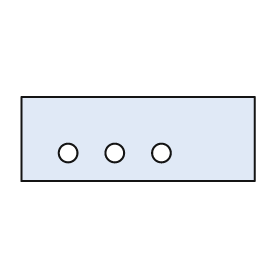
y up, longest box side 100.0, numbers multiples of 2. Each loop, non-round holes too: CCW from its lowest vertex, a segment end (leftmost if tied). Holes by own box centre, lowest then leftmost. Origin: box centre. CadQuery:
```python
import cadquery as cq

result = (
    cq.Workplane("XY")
    .moveTo(-50.0, -18.0)
    .lineTo(50.0, -18.0)
    .lineTo(50.0, 18.0)
    .lineTo(-50.0, 18.0)
    .close()
    .moveTo(-30.0, -6.0)
    .circle(4.0)
    .moveTo(-10.0, -6.0)
    .circle(4.0)
    .moveTo(10.0, -6.0)
    .circle(4.0)
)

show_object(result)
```